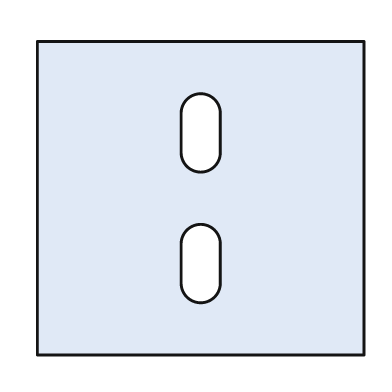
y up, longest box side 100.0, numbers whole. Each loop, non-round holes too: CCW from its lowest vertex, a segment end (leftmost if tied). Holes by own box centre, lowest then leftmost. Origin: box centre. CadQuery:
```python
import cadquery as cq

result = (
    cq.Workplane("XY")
    .moveTo(-50.0, -48.0)
    .lineTo(50.0, -48.0)
    .lineTo(50.0, 48.0)
    .lineTo(-50.0, 48.0)
    .close()
    .moveTo(-6.0, -26.0)
    .threePointArc((0.0, -32.0), (6.0, -26.0))
    .lineTo(6.0, -14.0)
    .threePointArc((0.0, -8.0), (-6.0, -14.0))
    .close()
    .moveTo(-6.0, 14.0)
    .threePointArc((0.0, 8.0), (6.0, 14.0))
    .lineTo(6.0, 26.0)
    .threePointArc((0.0, 32.0), (-6.0, 26.0))
    .close()
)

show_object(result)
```